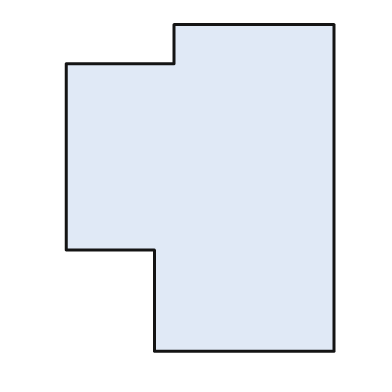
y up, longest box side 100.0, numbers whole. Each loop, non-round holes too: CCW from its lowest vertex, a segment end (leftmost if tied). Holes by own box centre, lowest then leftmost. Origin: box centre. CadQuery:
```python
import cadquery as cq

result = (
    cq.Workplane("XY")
    .moveTo(-14.0, -50.0)
    .lineTo(41.0, -50.0)
    .lineTo(41.0, 50.0)
    .lineTo(-8.0, 50.0)
    .lineTo(-8.0, 38.0)
    .lineTo(-41.0, 38.0)
    .lineTo(-41.0, -19.0)
    .lineTo(-14.0, -19.0)
    .close()
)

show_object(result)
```